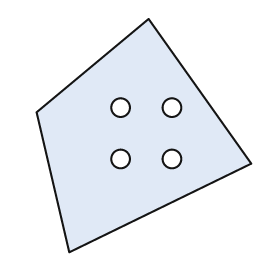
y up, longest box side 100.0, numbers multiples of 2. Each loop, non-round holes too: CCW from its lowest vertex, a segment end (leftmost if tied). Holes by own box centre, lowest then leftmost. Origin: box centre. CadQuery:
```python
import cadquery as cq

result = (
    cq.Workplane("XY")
    .moveTo(-32.0, -50.0)
    .lineTo(46.0, -12.0)
    .lineTo(2.0, 50.0)
    .lineTo(-46.0, 10.0)
    .close()
    .moveTo(-10.0, -10.0)
    .circle(4.0)
    .moveTo(12.0, -10.0)
    .circle(4.0)
    .moveTo(-10.0, 12.0)
    .circle(4.0)
    .moveTo(12.0, 12.0)
    .circle(4.0)
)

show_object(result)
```